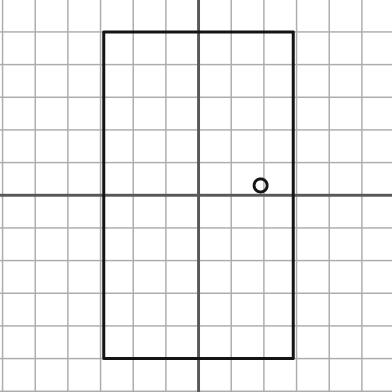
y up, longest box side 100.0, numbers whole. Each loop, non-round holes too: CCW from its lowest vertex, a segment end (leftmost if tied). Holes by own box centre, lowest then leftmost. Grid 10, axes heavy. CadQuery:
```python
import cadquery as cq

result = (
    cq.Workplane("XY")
    .moveTo(-29.0, -50.0)
    .lineTo(29.0, -50.0)
    .lineTo(29.0, 50.0)
    .lineTo(-29.0, 50.0)
    .close()
    .moveTo(19.0, 3.0)
    .circle(2.0)
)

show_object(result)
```